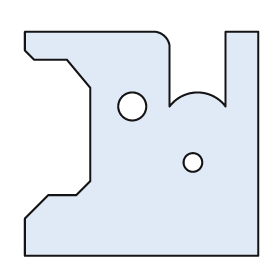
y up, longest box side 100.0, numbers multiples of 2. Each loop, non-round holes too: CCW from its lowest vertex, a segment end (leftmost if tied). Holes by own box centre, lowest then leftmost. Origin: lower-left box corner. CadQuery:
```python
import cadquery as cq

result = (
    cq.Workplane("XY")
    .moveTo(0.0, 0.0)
    .lineTo(100.0, 0.0)
    .lineTo(100.0, 96.0)
    .lineTo(86.0, 96.0)
    .lineTo(86.0, 64.0)
    .threePointArc((74.0, 70.0), (62.0, 64.0))
    .lineTo(62.0, 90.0)
    .threePointArc((60.0, 94.0), (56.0, 96.0))
    .lineTo(0.0, 96.0)
    .lineTo(0.0, 88.0)
    .lineTo(4.0, 84.0)
    .lineTo(18.0, 84.0)
    .lineTo(28.0, 72.0)
    .lineTo(28.0, 32.0)
    .lineTo(22.0, 26.0)
    .lineTo(10.0, 26.0)
    .lineTo(0.0, 16.0)
    .close()
    .moveTo(72.0, 40.0)
    .circle(4.0)
    .moveTo(46.0, 64.0)
    .circle(6.0)
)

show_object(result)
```